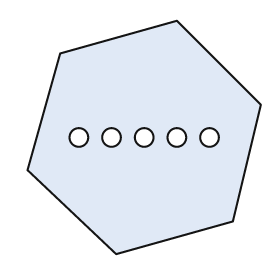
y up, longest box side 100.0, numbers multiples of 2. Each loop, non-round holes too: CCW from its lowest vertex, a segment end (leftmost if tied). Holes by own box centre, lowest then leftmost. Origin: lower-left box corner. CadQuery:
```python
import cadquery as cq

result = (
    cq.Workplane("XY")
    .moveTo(38.0, 0.0)
    .lineTo(88.0, 14.0)
    .lineTo(100.0, 64.0)
    .lineTo(64.0, 100.0)
    .lineTo(14.0, 86.0)
    .lineTo(0.0, 36.0)
    .close()
    .moveTo(22.0, 50.0)
    .circle(4.0)
    .moveTo(36.0, 50.0)
    .circle(4.0)
    .moveTo(50.0, 50.0)
    .circle(4.0)
    .moveTo(64.0, 50.0)
    .circle(4.0)
    .moveTo(78.0, 50.0)
    .circle(4.0)
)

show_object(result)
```